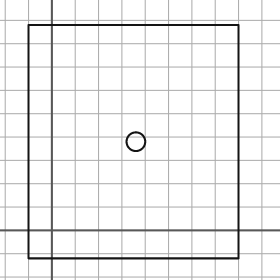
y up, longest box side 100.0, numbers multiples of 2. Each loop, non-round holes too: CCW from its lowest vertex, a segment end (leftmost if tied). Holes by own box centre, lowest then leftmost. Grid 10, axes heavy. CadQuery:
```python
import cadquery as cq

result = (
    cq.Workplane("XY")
    .moveTo(-10.0, -12.0)
    .lineTo(80.0, -12.0)
    .lineTo(80.0, 88.0)
    .lineTo(-10.0, 88.0)
    .close()
    .moveTo(36.0, 38.0)
    .circle(4.0)
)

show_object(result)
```